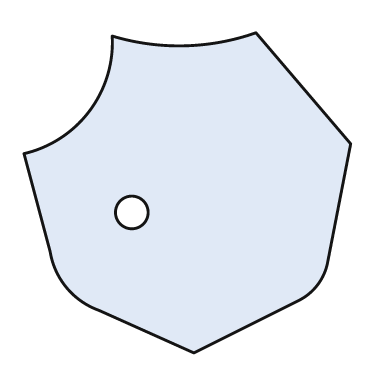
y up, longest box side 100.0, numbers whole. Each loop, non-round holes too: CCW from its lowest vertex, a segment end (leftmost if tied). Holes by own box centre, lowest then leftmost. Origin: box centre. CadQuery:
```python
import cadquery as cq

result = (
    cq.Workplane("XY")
    .moveTo(2.0, -49.0)
    .lineTo(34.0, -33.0)
    .threePointArc((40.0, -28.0), (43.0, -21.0))
    .lineTo(50.0, 15.0)
    .lineTo(21.0, 49.0)
    .threePointArc((-1.0, 45.0), (-23.0, 48.0))
    .threePointArc((-30.0, 25.0), (-50.0, 12.0))
    .lineTo(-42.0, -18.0)
    .threePointArc((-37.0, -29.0), (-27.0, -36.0))
    .close()
    .moveTo(-17.0, -6.0)
    .circle(5.0)
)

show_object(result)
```